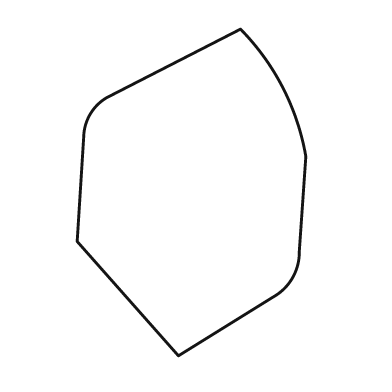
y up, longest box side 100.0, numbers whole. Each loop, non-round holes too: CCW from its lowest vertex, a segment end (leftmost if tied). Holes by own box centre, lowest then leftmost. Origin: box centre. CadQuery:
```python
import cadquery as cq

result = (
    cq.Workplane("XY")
    .moveTo(-4.0, -50.0)
    .lineTo(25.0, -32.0)
    .threePointArc((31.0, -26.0), (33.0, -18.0))
    .lineTo(35.0, 11.0)
    .threePointArc((28.0, 32.0), (15.0, 50.0))
    .lineTo(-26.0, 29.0)
    .threePointArc((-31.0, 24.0), (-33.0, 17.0))
    .lineTo(-35.0, -15.0)
    .close()
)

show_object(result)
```